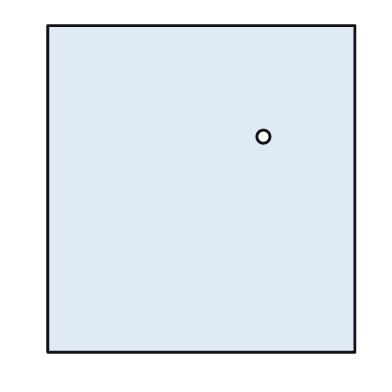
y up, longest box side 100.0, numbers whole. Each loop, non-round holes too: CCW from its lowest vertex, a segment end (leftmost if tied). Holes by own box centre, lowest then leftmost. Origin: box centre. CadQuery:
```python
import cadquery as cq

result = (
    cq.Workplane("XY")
    .moveTo(-47.0, -50.0)
    .lineTo(47.0, -50.0)
    .lineTo(47.0, 50.0)
    .lineTo(-47.0, 50.0)
    .close()
    .moveTo(19.0, 16.0)
    .circle(2.0)
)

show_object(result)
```